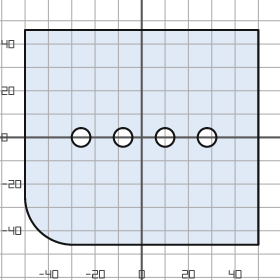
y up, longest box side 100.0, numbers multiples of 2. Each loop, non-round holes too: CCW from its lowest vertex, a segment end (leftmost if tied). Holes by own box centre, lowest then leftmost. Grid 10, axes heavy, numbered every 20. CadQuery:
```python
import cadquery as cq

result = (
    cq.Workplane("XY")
    .moveTo(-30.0, -46.0)
    .lineTo(50.0, -46.0)
    .lineTo(50.0, 46.0)
    .lineTo(-50.0, 46.0)
    .lineTo(-50.0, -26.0)
    .threePointArc((-44.0, -40.0), (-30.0, -46.0))
    .close()
    .moveTo(-26.0, 0.0)
    .circle(4.0)
    .moveTo(-8.0, 0.0)
    .circle(4.0)
    .moveTo(10.0, 0.0)
    .circle(4.0)
    .moveTo(28.0, 0.0)
    .circle(4.0)
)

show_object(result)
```